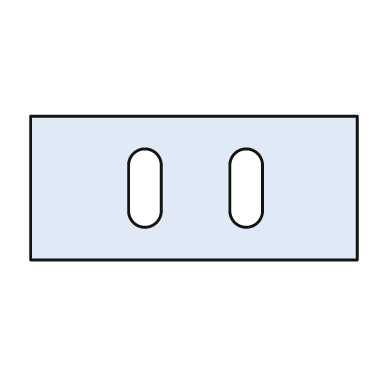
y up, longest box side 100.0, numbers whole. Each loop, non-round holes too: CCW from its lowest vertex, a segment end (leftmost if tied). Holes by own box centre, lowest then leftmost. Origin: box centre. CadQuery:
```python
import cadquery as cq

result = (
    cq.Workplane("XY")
    .moveTo(-50.0, -22.0)
    .lineTo(50.0, -22.0)
    .lineTo(50.0, 22.0)
    .lineTo(-50.0, 22.0)
    .close()
    .moveTo(-20.0, -7.0)
    .threePointArc((-15.0, -12.0), (-10.0, -7.0))
    .lineTo(-10.0, 7.0)
    .threePointArc((-15.0, 12.0), (-20.0, 7.0))
    .close()
    .moveTo(11.0, -7.0)
    .threePointArc((16.0, -12.0), (21.0, -7.0))
    .lineTo(21.0, 7.0)
    .threePointArc((16.0, 12.0), (11.0, 7.0))
    .close()
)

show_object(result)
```